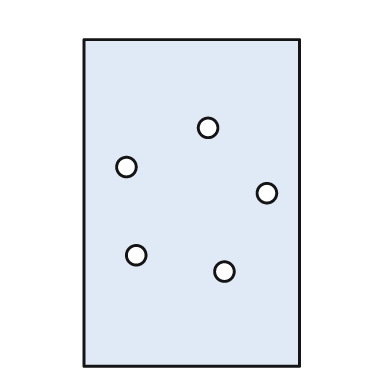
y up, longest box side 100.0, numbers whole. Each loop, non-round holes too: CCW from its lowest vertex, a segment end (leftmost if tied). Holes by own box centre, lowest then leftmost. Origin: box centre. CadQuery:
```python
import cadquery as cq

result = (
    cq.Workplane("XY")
    .moveTo(-33.0, -50.0)
    .lineTo(33.0, -50.0)
    .lineTo(33.0, 50.0)
    .lineTo(-33.0, 50.0)
    .close()
    .moveTo(10.0, -21.0)
    .circle(3.0)
    .moveTo(-17.0, -16.0)
    .circle(3.0)
    .moveTo(23.0, 3.0)
    .circle(3.0)
    .moveTo(-20.0, 11.0)
    .circle(3.0)
    .moveTo(5.0, 23.0)
    .circle(3.0)
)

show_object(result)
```